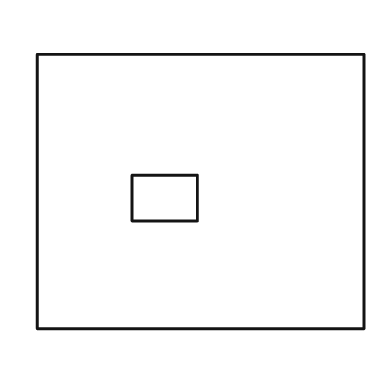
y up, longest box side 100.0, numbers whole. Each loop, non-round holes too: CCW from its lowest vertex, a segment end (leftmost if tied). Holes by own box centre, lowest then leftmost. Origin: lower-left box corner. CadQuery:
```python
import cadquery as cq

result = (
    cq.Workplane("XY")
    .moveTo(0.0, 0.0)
    .lineTo(100.0, 0.0)
    .lineTo(100.0, 84.0)
    .lineTo(0.0, 84.0)
    .close()
    .moveTo(29.0, 33.0)
    .lineTo(49.0, 33.0)
    .lineTo(49.0, 47.0)
    .lineTo(29.0, 47.0)
    .close()
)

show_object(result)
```